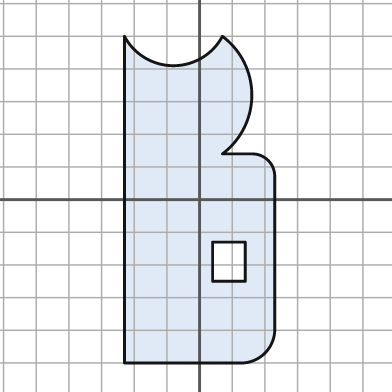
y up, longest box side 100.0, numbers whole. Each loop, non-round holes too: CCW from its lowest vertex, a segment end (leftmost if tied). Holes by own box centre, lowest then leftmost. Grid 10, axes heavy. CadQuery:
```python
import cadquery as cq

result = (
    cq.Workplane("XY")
    .moveTo(-23.0, -50.0)
    .lineTo(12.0, -50.0)
    .threePointArc((20.0, -47.0), (23.0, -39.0))
    .lineTo(23.0, 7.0)
    .threePointArc((21.0, 12.0), (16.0, 14.0))
    .lineTo(7.0, 14.0)
    .threePointArc((16.0, 32.0), (7.0, 50.0))
    .threePointArc((-8.0, 41.0), (-23.0, 50.0))
    .close()
    .moveTo(4.0, -25.0)
    .lineTo(14.0, -25.0)
    .lineTo(14.0, -13.0)
    .lineTo(4.0, -13.0)
    .close()
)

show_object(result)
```